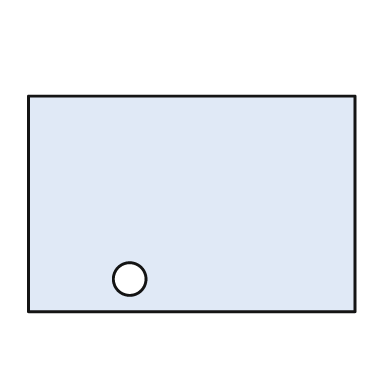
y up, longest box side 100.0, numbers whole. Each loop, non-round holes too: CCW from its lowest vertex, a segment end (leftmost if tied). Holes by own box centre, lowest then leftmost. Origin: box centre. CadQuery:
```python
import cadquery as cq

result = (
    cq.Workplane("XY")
    .moveTo(-50.0, -33.0)
    .lineTo(50.0, -33.0)
    .lineTo(50.0, 33.0)
    .lineTo(-50.0, 33.0)
    .close()
    .moveTo(-19.0, -23.0)
    .circle(5.0)
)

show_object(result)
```